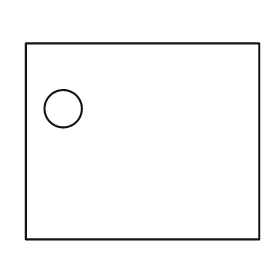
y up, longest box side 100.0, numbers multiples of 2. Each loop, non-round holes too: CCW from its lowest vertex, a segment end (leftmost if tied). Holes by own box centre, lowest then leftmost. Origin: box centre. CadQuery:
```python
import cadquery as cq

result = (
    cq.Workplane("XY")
    .moveTo(-50.0, -42.0)
    .lineTo(50.0, -42.0)
    .lineTo(50.0, 42.0)
    .lineTo(-50.0, 42.0)
    .close()
    .moveTo(-34.0, 14.0)
    .circle(8.0)
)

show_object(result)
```